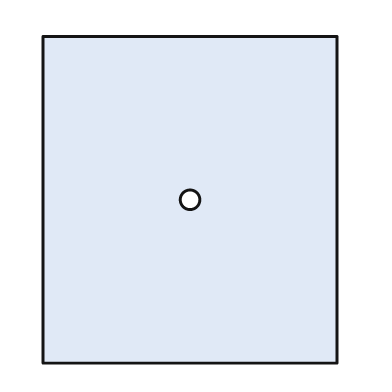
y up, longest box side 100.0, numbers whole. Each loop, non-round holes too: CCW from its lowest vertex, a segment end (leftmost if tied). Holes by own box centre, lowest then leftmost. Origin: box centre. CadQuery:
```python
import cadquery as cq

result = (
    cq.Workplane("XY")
    .moveTo(-45.0, -50.0)
    .lineTo(45.0, -50.0)
    .lineTo(45.0, 50.0)
    .lineTo(-45.0, 50.0)
    .close()
    .moveTo(0.0, 0.0)
    .circle(3.0)
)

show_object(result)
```